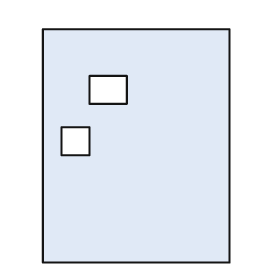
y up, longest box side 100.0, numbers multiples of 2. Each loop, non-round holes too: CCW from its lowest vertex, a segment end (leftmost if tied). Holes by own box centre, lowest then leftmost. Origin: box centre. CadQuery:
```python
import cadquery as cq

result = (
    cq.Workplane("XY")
    .moveTo(-40.0, -50.0)
    .lineTo(40.0, -50.0)
    .lineTo(40.0, 50.0)
    .lineTo(-40.0, 50.0)
    .close()
    .moveTo(-32.0, -4.0)
    .lineTo(-20.0, -4.0)
    .lineTo(-20.0, 8.0)
    .lineTo(-32.0, 8.0)
    .close()
    .moveTo(-20.0, 18.0)
    .lineTo(-4.0, 18.0)
    .lineTo(-4.0, 30.0)
    .lineTo(-20.0, 30.0)
    .close()
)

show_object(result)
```